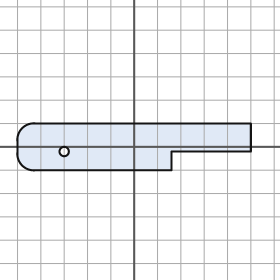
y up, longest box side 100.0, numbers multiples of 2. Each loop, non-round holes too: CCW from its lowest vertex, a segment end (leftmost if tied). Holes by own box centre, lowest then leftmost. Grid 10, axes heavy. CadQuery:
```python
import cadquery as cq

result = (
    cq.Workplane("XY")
    .moveTo(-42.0, -10.0)
    .lineTo(16.0, -10.0)
    .lineTo(16.0, -2.0)
    .lineTo(50.0, -2.0)
    .lineTo(50.0, 10.0)
    .lineTo(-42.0, 10.0)
    .threePointArc((-48.0, 8.0), (-50.0, 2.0))
    .lineTo(-50.0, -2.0)
    .threePointArc((-48.0, -8.0), (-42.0, -10.0))
    .close()
    .moveTo(-30.0, -2.0)
    .circle(2.0)
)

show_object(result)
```